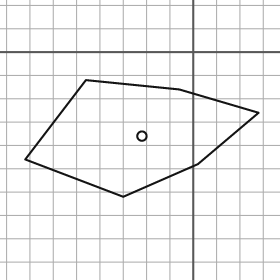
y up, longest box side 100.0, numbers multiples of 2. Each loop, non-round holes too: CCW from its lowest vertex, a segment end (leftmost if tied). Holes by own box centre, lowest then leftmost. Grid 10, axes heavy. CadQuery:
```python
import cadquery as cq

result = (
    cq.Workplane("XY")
    .moveTo(-30.0, -62.0)
    .lineTo(2.0, -48.0)
    .lineTo(28.0, -26.0)
    .lineTo(-6.0, -16.0)
    .lineTo(-46.0, -12.0)
    .lineTo(-72.0, -46.0)
    .close()
    .moveTo(-22.0, -36.0)
    .circle(2.0)
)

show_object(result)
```